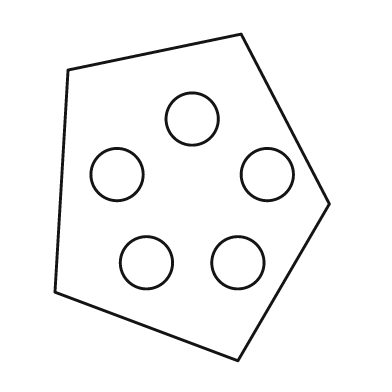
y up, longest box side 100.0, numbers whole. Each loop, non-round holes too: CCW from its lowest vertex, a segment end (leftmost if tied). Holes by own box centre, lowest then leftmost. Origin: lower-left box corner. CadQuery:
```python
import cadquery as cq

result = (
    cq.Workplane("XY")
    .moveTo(56.0, 0.0)
    .lineTo(84.0, 48.0)
    .lineTo(57.0, 100.0)
    .lineTo(4.0, 89.0)
    .lineTo(0.0, 21.0)
    .close()
    .moveTo(28.0, 30.0)
    .circle(8.0)
    .moveTo(56.0, 30.0)
    .circle(8.0)
    .moveTo(19.0, 57.0)
    .circle(8.0)
    .moveTo(65.0, 57.0)
    .circle(8.0)
    .moveTo(42.0, 74.0)
    .circle(8.0)
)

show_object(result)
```